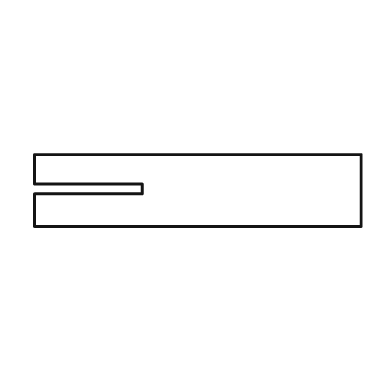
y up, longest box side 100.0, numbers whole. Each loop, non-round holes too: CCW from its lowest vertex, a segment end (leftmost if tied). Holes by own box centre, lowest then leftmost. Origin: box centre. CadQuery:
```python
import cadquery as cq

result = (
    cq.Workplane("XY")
    .moveTo(-50.0, -11.0)
    .lineTo(50.0, -11.0)
    .lineTo(50.0, 11.0)
    .lineTo(-50.0, 11.0)
    .lineTo(-50.0, 2.0)
    .lineTo(-17.0, 2.0)
    .lineTo(-17.0, -1.0)
    .lineTo(-50.0, -1.0)
    .close()
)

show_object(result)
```